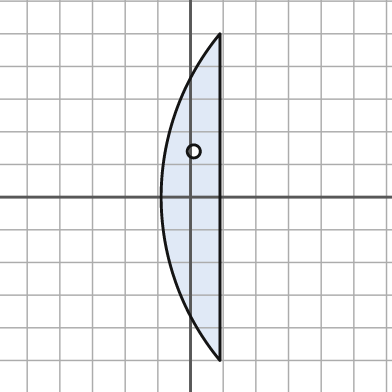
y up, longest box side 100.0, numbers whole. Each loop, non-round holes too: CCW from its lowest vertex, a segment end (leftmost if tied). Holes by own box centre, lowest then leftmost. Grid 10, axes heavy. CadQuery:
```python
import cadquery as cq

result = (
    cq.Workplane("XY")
    .moveTo(9.0, -50.0)
    .lineTo(9.0, 50.0)
    .threePointArc((-9.0, 0.0), (9.0, -50.0))
    .close()
    .moveTo(1.0, 14.0)
    .circle(2.0)
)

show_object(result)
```